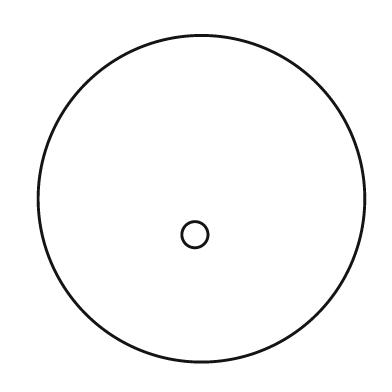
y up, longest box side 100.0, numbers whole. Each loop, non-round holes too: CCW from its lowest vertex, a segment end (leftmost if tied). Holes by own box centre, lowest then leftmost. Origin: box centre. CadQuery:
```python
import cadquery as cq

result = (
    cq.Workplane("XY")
    .moveTo(0.0, 0.0)
    .circle(50.0)
    .moveTo(-2.0, -11.0)
    .circle(4.0)
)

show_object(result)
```